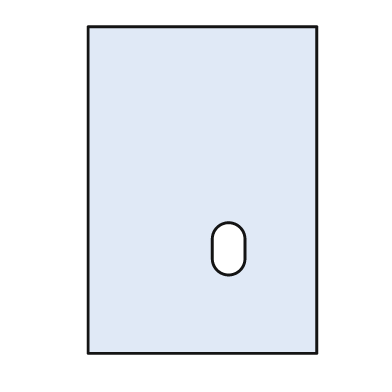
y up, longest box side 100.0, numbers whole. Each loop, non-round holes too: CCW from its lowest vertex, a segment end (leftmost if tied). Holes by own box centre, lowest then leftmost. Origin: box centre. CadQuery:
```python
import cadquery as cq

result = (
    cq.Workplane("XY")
    .moveTo(-35.0, -50.0)
    .lineTo(35.0, -50.0)
    .lineTo(35.0, 50.0)
    .lineTo(-35.0, 50.0)
    .close()
    .moveTo(3.0, -21.0)
    .threePointArc((8.0, -26.0), (13.0, -21.0))
    .lineTo(13.0, -15.0)
    .threePointArc((8.0, -10.0), (3.0, -15.0))
    .close()
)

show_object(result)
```